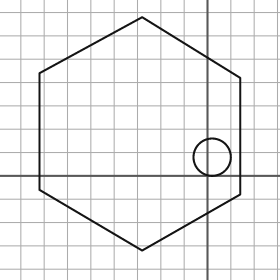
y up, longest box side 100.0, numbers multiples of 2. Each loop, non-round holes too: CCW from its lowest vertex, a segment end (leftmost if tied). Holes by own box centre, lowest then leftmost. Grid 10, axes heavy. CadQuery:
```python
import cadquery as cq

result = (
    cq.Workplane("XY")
    .moveTo(-28.0, -32.0)
    .lineTo(14.0, -8.0)
    .lineTo(14.0, 42.0)
    .lineTo(-28.0, 68.0)
    .lineTo(-72.0, 44.0)
    .lineTo(-72.0, -6.0)
    .close()
    .moveTo(2.0, 8.0)
    .circle(8.0)
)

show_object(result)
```